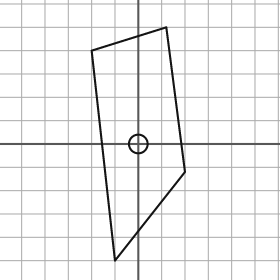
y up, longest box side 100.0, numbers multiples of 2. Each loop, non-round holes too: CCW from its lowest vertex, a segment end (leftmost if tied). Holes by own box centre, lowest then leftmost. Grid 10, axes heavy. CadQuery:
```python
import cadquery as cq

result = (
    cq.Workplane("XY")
    .moveTo(-10.0, -50.0)
    .lineTo(20.0, -12.0)
    .lineTo(12.0, 50.0)
    .lineTo(-20.0, 40.0)
    .close()
    .moveTo(0.0, 0.0)
    .circle(4.0)
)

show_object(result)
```